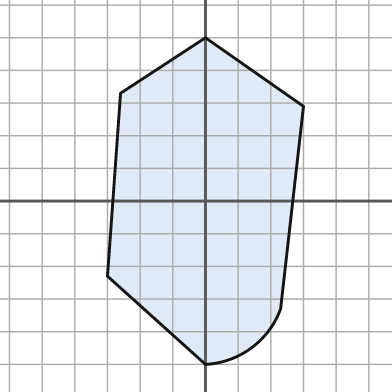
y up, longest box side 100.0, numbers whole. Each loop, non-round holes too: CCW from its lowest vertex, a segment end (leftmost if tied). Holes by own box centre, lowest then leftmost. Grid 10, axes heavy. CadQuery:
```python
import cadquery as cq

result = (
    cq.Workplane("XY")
    .moveTo(0.0, -50.0)
    .threePointArc((14.0, -45.0), (23.0, -33.0))
    .lineTo(30.0, 29.0)
    .lineTo(0.0, 50.0)
    .lineTo(-26.0, 33.0)
    .lineTo(-30.0, -23.0)
    .close()
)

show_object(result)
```